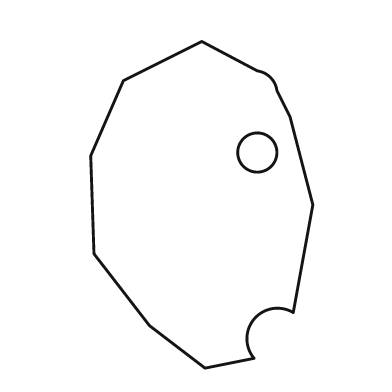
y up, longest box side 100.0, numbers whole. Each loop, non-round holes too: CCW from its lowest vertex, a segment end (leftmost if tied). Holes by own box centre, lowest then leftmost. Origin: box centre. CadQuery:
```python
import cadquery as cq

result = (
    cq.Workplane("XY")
    .moveTo(1.0, -50.0)
    .lineTo(16.0, -47.0)
    .threePointArc((16.0, -35.0), (28.0, -33.0))
    .lineTo(34.0, 0.0)
    .lineTo(27.0, 27.0)
    .lineTo(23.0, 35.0)
    .threePointArc((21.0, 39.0), (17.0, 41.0))
    .lineTo(0.0, 50.0)
    .lineTo(-24.0, 38.0)
    .lineTo(-34.0, 15.0)
    .lineTo(-33.0, -15.0)
    .lineTo(-16.0, -37.0)
    .close()
    .moveTo(17.0, 16.0)
    .circle(6.0)
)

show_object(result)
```